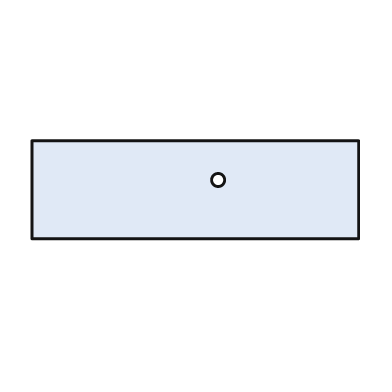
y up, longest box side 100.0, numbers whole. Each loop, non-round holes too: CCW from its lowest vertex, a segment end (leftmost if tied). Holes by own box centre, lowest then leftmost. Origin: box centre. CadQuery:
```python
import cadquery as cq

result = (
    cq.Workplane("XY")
    .moveTo(-50.0, -15.0)
    .lineTo(50.0, -15.0)
    .lineTo(50.0, 15.0)
    .lineTo(-50.0, 15.0)
    .close()
    .moveTo(7.0, 3.0)
    .circle(2.0)
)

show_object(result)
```